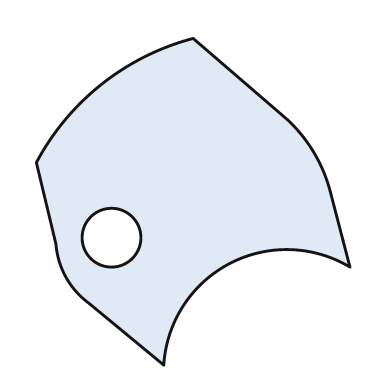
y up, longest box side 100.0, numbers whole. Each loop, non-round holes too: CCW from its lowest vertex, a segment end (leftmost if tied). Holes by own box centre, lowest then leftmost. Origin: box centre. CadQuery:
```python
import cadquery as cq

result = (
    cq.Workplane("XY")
    .moveTo(-9.0, -50.0)
    .threePointArc((11.0, -19.0), (48.0, -20.0))
    .lineTo(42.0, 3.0)
    .threePointArc((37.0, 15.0), (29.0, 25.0))
    .lineTo(0.0, 50.0)
    .threePointArc((-28.0, 36.0), (-48.0, 12.0))
    .lineTo(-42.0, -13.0)
    .threePointArc((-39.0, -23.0), (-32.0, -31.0))
    .close()
    .moveTo(-25.0, -11.0)
    .circle(9.0)
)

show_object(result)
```